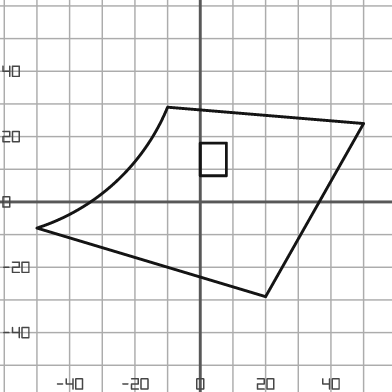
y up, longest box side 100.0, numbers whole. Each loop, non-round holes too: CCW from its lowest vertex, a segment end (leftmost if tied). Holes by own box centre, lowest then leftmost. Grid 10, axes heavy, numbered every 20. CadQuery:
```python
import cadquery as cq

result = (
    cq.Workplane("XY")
    .moveTo(20.0, -29.0)
    .lineTo(50.0, 24.0)
    .lineTo(-10.0, 29.0)
    .threePointArc((-26.0, 6.0), (-50.0, -8.0))
    .close()
    .moveTo(0.0, 8.0)
    .lineTo(8.0, 8.0)
    .lineTo(8.0, 18.0)
    .lineTo(0.0, 18.0)
    .close()
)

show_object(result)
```